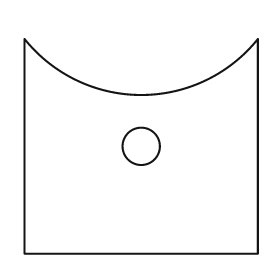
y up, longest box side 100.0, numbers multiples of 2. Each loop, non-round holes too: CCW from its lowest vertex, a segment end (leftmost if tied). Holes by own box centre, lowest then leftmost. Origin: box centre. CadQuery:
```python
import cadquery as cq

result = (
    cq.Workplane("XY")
    .moveTo(-50.0, -46.0)
    .lineTo(50.0, -46.0)
    .lineTo(50.0, 46.0)
    .threePointArc((0.0, 22.0), (-50.0, 46.0))
    .close()
    .moveTo(0.0, 0.0)
    .circle(8.0)
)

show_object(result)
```